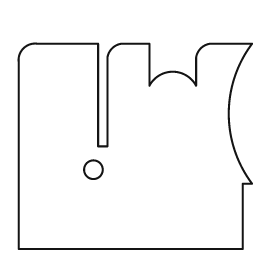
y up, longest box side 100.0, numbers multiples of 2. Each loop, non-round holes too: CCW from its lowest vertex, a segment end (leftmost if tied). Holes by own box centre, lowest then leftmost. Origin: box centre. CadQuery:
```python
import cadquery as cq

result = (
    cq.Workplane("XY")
    .moveTo(-50.0, -44.0)
    .lineTo(46.0, -44.0)
    .lineTo(46.0, -16.0)
    .lineTo(50.0, -16.0)
    .threePointArc((40.0, 14.0), (50.0, 44.0))
    .lineTo(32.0, 44.0)
    .threePointArc((28.0, 42.0), (26.0, 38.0))
    .lineTo(26.0, 26.0)
    .threePointArc((16.0, 32.0), (6.0, 26.0))
    .lineTo(6.0, 44.0)
    .lineTo(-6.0, 44.0)
    .threePointArc((-10.0, 42.0), (-12.0, 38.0))
    .lineTo(-12.0, 0.0)
    .lineTo(-16.0, 0.0)
    .lineTo(-16.0, 44.0)
    .lineTo(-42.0, 44.0)
    .threePointArc((-48.0, 42.0), (-50.0, 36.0))
    .close()
    .moveTo(-18.0, -10.0)
    .circle(4.0)
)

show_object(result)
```